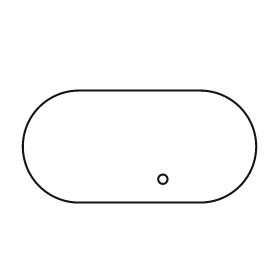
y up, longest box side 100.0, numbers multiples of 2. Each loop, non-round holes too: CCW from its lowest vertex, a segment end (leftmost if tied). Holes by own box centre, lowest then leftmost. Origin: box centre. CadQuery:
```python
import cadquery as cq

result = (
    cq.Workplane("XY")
    .moveTo(-26.0, -24.0)
    .lineTo(26.0, -24.0)
    .threePointArc((50.0, 0.0), (26.0, 24.0))
    .lineTo(-26.0, 24.0)
    .threePointArc((-50.0, 0.0), (-26.0, -24.0))
    .close()
    .moveTo(10.0, -14.0)
    .circle(2.0)
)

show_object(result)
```